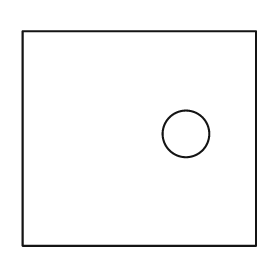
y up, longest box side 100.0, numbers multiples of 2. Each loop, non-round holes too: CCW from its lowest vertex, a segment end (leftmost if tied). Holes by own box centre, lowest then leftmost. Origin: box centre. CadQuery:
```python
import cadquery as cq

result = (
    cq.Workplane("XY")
    .moveTo(-50.0, -46.0)
    .lineTo(50.0, -46.0)
    .lineTo(50.0, 46.0)
    .lineTo(-50.0, 46.0)
    .close()
    .moveTo(20.0, 2.0)
    .circle(10.0)
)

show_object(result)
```